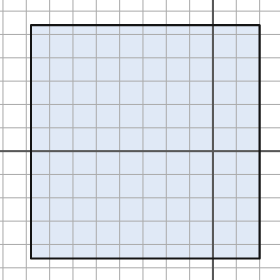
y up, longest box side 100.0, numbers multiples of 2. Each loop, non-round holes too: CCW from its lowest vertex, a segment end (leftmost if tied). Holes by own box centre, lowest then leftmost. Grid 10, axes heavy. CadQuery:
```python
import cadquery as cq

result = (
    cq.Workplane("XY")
    .moveTo(-78.0, -46.0)
    .lineTo(20.0, -46.0)
    .lineTo(20.0, 54.0)
    .lineTo(-78.0, 54.0)
    .close()
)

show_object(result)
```